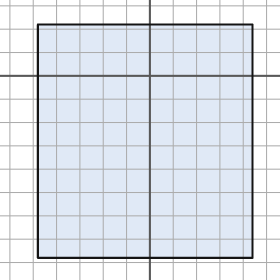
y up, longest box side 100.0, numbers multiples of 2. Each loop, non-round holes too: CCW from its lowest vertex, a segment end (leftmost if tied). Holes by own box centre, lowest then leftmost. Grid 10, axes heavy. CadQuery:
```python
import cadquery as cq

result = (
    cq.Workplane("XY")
    .moveTo(-48.0, -78.0)
    .lineTo(44.0, -78.0)
    .lineTo(44.0, 22.0)
    .lineTo(-48.0, 22.0)
    .close()
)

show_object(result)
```